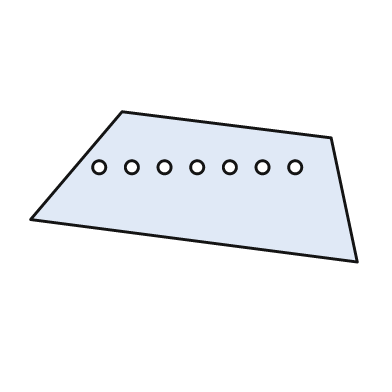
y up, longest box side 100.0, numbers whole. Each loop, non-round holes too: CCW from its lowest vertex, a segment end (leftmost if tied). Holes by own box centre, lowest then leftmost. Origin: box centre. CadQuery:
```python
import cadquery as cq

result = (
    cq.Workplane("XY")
    .moveTo(50.0, -23.0)
    .lineTo(42.0, 15.0)
    .lineTo(-22.0, 23.0)
    .lineTo(-50.0, -10.0)
    .close()
    .moveTo(-29.0, 6.0)
    .circle(2.0)
    .moveTo(-19.0, 6.0)
    .circle(2.0)
    .moveTo(-9.0, 6.0)
    .circle(2.0)
    .moveTo(1.0, 6.0)
    .circle(2.0)
    .moveTo(11.0, 6.0)
    .circle(2.0)
    .moveTo(21.0, 6.0)
    .circle(2.0)
    .moveTo(31.0, 6.0)
    .circle(2.0)
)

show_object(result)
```